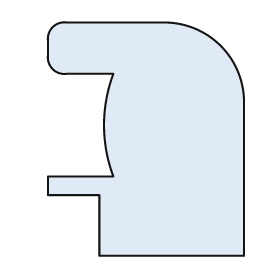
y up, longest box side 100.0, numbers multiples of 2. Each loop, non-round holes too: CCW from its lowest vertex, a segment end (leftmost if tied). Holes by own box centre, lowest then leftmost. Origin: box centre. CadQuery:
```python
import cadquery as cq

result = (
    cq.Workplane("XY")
    .moveTo(-20.0, -50.0)
    .lineTo(42.0, -50.0)
    .lineTo(42.0, 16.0)
    .threePointArc((32.0, 40.0), (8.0, 50.0))
    .lineTo(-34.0, 50.0)
    .threePointArc((-40.0, 48.0), (-42.0, 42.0))
    .lineTo(-42.0, 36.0)
    .threePointArc((-40.0, 30.0), (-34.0, 28.0))
    .lineTo(-14.0, 28.0)
    .threePointArc((-18.0, 6.0), (-14.0, -16.0))
    .lineTo(-42.0, -16.0)
    .lineTo(-42.0, -24.0)
    .lineTo(-20.0, -24.0)
    .close()
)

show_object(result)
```